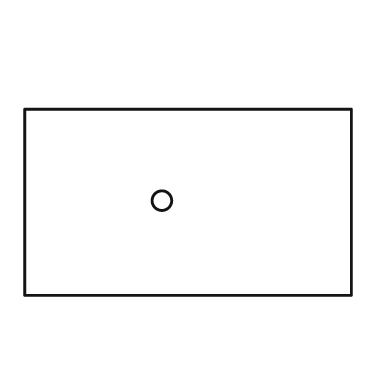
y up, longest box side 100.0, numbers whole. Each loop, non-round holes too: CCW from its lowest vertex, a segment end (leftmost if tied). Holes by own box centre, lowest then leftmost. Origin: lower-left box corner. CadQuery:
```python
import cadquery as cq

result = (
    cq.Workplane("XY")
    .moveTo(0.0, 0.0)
    .lineTo(100.0, 0.0)
    .lineTo(100.0, 57.0)
    .lineTo(0.0, 57.0)
    .close()
    .moveTo(42.0, 29.0)
    .circle(3.0)
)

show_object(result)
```